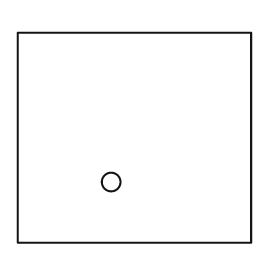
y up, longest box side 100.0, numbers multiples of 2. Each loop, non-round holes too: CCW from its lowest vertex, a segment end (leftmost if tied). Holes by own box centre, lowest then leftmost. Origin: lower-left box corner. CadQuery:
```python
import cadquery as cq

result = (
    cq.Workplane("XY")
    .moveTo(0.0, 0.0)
    .lineTo(100.0, 0.0)
    .lineTo(100.0, 90.0)
    .lineTo(0.0, 90.0)
    .close()
    .moveTo(40.0, 26.0)
    .circle(4.0)
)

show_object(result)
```